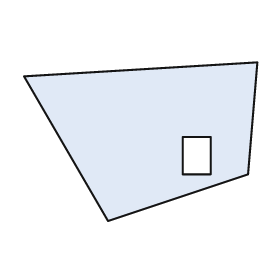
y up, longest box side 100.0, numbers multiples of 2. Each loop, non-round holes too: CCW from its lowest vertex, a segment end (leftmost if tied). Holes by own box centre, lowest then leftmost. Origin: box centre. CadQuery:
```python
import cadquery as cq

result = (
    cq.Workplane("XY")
    .moveTo(-14.0, -34.0)
    .lineTo(46.0, -14.0)
    .lineTo(50.0, 34.0)
    .lineTo(-50.0, 28.0)
    .close()
    .moveTo(18.0, -14.0)
    .lineTo(30.0, -14.0)
    .lineTo(30.0, 2.0)
    .lineTo(18.0, 2.0)
    .close()
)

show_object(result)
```